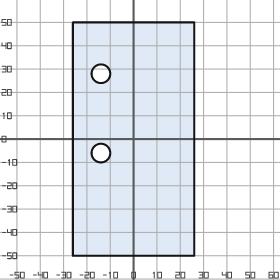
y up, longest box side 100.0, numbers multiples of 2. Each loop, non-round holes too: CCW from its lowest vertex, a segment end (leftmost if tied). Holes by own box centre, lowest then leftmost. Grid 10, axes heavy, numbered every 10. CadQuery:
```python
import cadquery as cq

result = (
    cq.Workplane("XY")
    .moveTo(-26.0, -50.0)
    .lineTo(26.0, -50.0)
    .lineTo(26.0, 50.0)
    .lineTo(-26.0, 50.0)
    .close()
    .moveTo(-14.0, -6.0)
    .circle(4.0)
    .moveTo(-14.0, 28.0)
    .circle(4.0)
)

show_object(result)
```